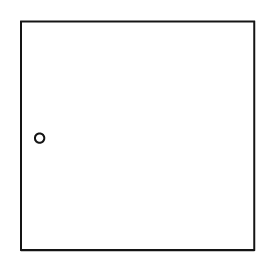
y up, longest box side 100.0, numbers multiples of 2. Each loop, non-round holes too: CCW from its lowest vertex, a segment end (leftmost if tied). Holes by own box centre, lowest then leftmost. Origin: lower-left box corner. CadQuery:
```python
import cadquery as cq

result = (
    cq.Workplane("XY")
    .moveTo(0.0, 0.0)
    .lineTo(100.0, 0.0)
    .lineTo(100.0, 98.0)
    .lineTo(0.0, 98.0)
    .close()
    .moveTo(8.0, 48.0)
    .circle(2.0)
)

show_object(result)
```